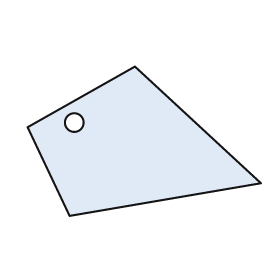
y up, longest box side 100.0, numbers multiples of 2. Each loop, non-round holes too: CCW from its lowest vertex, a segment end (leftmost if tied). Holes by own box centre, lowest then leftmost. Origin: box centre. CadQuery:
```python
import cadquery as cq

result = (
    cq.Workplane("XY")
    .moveTo(-32.0, -32.0)
    .lineTo(50.0, -18.0)
    .lineTo(-4.0, 32.0)
    .lineTo(-50.0, 6.0)
    .close()
    .moveTo(-30.0, 8.0)
    .circle(4.0)
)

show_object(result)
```